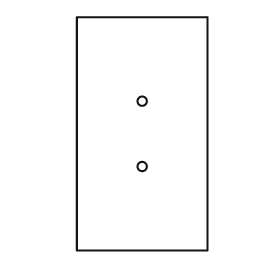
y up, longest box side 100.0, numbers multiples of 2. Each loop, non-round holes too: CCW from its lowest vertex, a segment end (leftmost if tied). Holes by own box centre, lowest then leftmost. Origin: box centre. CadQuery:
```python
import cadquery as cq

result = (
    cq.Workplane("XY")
    .moveTo(-28.0, -50.0)
    .lineTo(28.0, -50.0)
    .lineTo(28.0, 50.0)
    .lineTo(-28.0, 50.0)
    .close()
    .moveTo(0.0, -14.0)
    .circle(2.0)
    .moveTo(0.0, 14.0)
    .circle(2.0)
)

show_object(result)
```